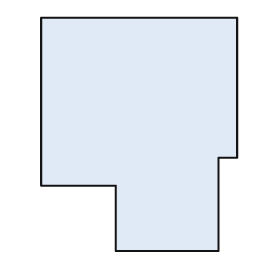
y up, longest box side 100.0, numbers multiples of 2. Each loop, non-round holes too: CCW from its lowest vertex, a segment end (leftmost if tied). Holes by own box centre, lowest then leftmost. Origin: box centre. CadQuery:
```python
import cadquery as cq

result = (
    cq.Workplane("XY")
    .moveTo(-10.0, -50.0)
    .lineTo(34.0, -50.0)
    .lineTo(34.0, -10.0)
    .lineTo(42.0, -10.0)
    .lineTo(42.0, 50.0)
    .lineTo(-42.0, 50.0)
    .lineTo(-42.0, -22.0)
    .lineTo(-10.0, -22.0)
    .close()
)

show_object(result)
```